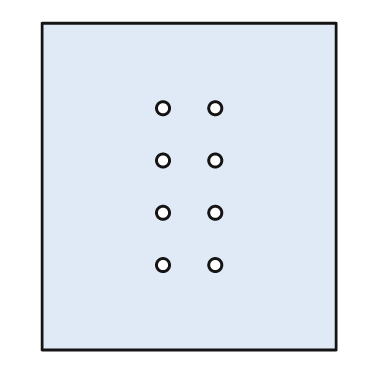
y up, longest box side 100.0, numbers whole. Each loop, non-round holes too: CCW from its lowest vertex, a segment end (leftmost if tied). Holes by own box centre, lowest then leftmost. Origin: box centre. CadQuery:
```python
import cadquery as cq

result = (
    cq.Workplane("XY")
    .moveTo(-45.0, -50.0)
    .lineTo(45.0, -50.0)
    .lineTo(45.0, 50.0)
    .lineTo(-45.0, 50.0)
    .close()
    .moveTo(-8.0, -24.0)
    .circle(2.0)
    .moveTo(8.0, -24.0)
    .circle(2.0)
    .moveTo(-8.0, -8.0)
    .circle(2.0)
    .moveTo(8.0, -8.0)
    .circle(2.0)
    .moveTo(-8.0, 8.0)
    .circle(2.0)
    .moveTo(8.0, 8.0)
    .circle(2.0)
    .moveTo(-8.0, 24.0)
    .circle(2.0)
    .moveTo(8.0, 24.0)
    .circle(2.0)
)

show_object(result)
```